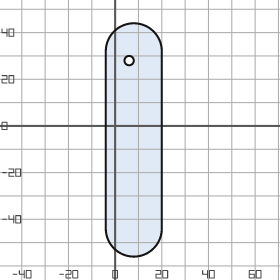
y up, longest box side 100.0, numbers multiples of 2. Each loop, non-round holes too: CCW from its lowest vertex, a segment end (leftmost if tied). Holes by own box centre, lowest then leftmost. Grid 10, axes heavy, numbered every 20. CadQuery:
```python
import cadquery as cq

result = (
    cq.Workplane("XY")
    .moveTo(-4.0, -44.0)
    .threePointArc((8.0, -56.0), (20.0, -44.0))
    .lineTo(20.0, 32.0)
    .threePointArc((8.0, 44.0), (-4.0, 32.0))
    .close()
    .moveTo(6.0, 28.0)
    .circle(2.0)
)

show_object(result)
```